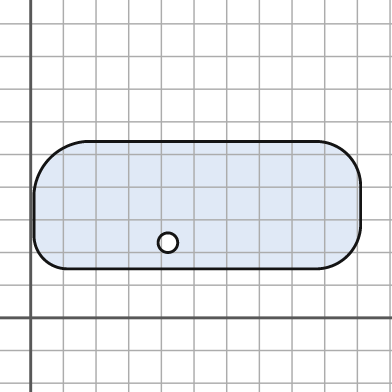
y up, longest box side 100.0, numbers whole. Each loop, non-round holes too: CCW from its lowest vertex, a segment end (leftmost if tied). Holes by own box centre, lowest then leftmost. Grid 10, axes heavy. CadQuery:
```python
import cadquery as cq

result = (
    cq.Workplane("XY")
    .moveTo(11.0, 15.0)
    .lineTo(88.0, 15.0)
    .threePointArc((97.0, 19.0), (101.0, 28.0))
    .lineTo(101.0, 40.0)
    .threePointArc((97.0, 50.0), (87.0, 54.0))
    .lineTo(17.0, 54.0)
    .threePointArc((6.0, 49.0), (1.0, 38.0))
    .lineTo(1.0, 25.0)
    .threePointArc((4.0, 18.0), (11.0, 15.0))
    .close()
    .moveTo(42.0, 23.0)
    .circle(3.0)
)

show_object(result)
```